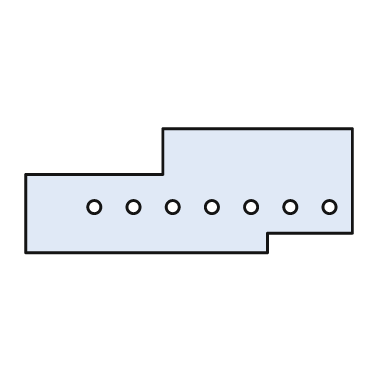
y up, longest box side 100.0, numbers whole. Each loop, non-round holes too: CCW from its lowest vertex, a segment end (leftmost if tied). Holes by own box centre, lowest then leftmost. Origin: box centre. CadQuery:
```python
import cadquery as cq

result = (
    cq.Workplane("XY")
    .moveTo(-50.0, -19.0)
    .lineTo(24.0, -19.0)
    .lineTo(24.0, -13.0)
    .lineTo(50.0, -13.0)
    .lineTo(50.0, 19.0)
    .lineTo(-8.0, 19.0)
    .lineTo(-8.0, 5.0)
    .lineTo(-50.0, 5.0)
    .close()
    .moveTo(-29.0, -5.0)
    .circle(2.0)
    .moveTo(-17.0, -5.0)
    .circle(2.0)
    .moveTo(-5.0, -5.0)
    .circle(2.0)
    .moveTo(7.0, -5.0)
    .circle(2.0)
    .moveTo(19.0, -5.0)
    .circle(2.0)
    .moveTo(31.0, -5.0)
    .circle(2.0)
    .moveTo(43.0, -5.0)
    .circle(2.0)
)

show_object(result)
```